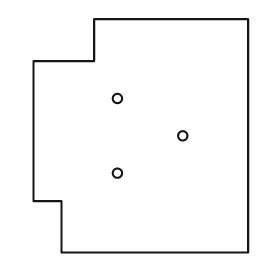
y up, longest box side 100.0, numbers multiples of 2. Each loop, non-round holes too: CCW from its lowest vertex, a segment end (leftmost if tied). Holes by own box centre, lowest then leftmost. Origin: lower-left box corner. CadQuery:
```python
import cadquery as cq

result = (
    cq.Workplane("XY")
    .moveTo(12.0, 0.0)
    .lineTo(92.0, 0.0)
    .lineTo(92.0, 100.0)
    .lineTo(26.0, 100.0)
    .lineTo(26.0, 82.0)
    .lineTo(0.0, 82.0)
    .lineTo(0.0, 22.0)
    .lineTo(12.0, 22.0)
    .close()
    .moveTo(36.0, 34.0)
    .circle(2.0)
    .moveTo(64.0, 50.0)
    .circle(2.0)
    .moveTo(36.0, 66.0)
    .circle(2.0)
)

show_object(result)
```